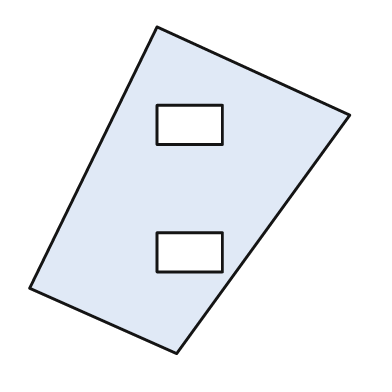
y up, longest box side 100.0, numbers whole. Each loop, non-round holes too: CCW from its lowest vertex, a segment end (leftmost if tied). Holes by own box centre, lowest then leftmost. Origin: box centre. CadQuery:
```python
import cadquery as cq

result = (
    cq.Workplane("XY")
    .moveTo(-4.0, -50.0)
    .lineTo(49.0, 23.0)
    .lineTo(-10.0, 50.0)
    .lineTo(-49.0, -30.0)
    .close()
    .moveTo(-10.0, -25.0)
    .lineTo(10.0, -25.0)
    .lineTo(10.0, -13.0)
    .lineTo(-10.0, -13.0)
    .close()
    .moveTo(-10.0, 14.0)
    .lineTo(10.0, 14.0)
    .lineTo(10.0, 26.0)
    .lineTo(-10.0, 26.0)
    .close()
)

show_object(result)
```